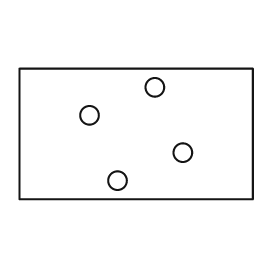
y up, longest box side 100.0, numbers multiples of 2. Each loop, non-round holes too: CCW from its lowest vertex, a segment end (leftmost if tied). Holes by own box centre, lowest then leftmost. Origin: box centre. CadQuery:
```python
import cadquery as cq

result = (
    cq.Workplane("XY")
    .moveTo(-50.0, -28.0)
    .lineTo(50.0, -28.0)
    .lineTo(50.0, 28.0)
    .lineTo(-50.0, 28.0)
    .close()
    .moveTo(-8.0, -20.0)
    .circle(4.0)
    .moveTo(20.0, -8.0)
    .circle(4.0)
    .moveTo(-20.0, 8.0)
    .circle(4.0)
    .moveTo(8.0, 20.0)
    .circle(4.0)
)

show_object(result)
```